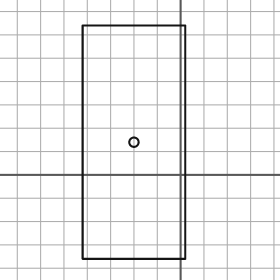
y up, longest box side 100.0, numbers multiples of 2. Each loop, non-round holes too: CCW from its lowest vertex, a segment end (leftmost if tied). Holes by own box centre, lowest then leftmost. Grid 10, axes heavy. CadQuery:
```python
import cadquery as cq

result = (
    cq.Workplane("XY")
    .moveTo(-42.0, -36.0)
    .lineTo(2.0, -36.0)
    .lineTo(2.0, 64.0)
    .lineTo(-42.0, 64.0)
    .close()
    .moveTo(-20.0, 14.0)
    .circle(2.0)
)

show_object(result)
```